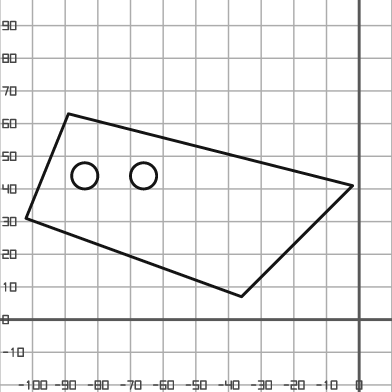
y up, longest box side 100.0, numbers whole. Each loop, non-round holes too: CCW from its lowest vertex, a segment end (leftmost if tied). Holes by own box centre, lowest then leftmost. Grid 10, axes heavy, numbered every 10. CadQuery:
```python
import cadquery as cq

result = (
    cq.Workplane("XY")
    .moveTo(-36.0, 7.0)
    .lineTo(-2.0, 41.0)
    .lineTo(-89.0, 63.0)
    .lineTo(-102.0, 31.0)
    .close()
    .moveTo(-84.0, 44.0)
    .circle(4.0)
    .moveTo(-66.0, 44.0)
    .circle(4.0)
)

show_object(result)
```